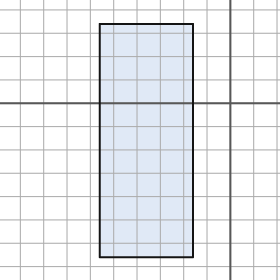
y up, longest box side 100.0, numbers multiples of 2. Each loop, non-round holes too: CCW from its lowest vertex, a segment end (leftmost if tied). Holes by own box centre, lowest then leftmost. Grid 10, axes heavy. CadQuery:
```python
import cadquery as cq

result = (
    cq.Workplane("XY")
    .moveTo(-56.0, -66.0)
    .lineTo(-16.0, -66.0)
    .lineTo(-16.0, 34.0)
    .lineTo(-56.0, 34.0)
    .close()
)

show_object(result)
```